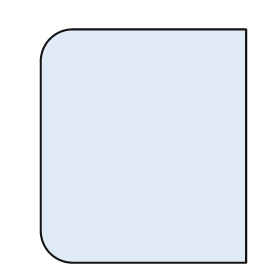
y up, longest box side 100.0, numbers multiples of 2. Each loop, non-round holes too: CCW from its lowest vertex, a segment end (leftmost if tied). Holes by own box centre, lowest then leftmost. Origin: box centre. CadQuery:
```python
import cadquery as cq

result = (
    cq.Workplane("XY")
    .moveTo(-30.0, -50.0)
    .lineTo(44.0, -50.0)
    .lineTo(44.0, 50.0)
    .lineTo(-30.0, 50.0)
    .threePointArc((-40.0, 46.0), (-44.0, 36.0))
    .lineTo(-44.0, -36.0)
    .threePointArc((-40.0, -46.0), (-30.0, -50.0))
    .close()
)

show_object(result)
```